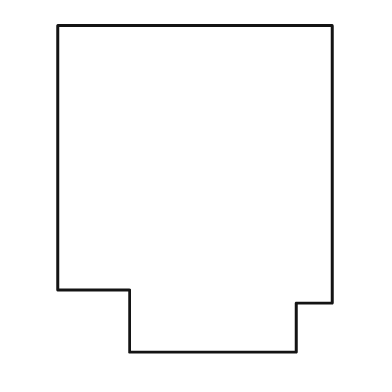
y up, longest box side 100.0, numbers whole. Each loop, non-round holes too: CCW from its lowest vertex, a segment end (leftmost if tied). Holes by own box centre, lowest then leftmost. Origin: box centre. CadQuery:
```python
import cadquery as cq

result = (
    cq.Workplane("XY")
    .moveTo(-20.0, -50.0)
    .lineTo(31.0, -50.0)
    .lineTo(31.0, -35.0)
    .lineTo(42.0, -35.0)
    .lineTo(42.0, 50.0)
    .lineTo(-42.0, 50.0)
    .lineTo(-42.0, -31.0)
    .lineTo(-20.0, -31.0)
    .close()
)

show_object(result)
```